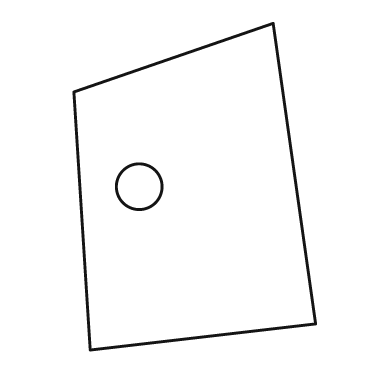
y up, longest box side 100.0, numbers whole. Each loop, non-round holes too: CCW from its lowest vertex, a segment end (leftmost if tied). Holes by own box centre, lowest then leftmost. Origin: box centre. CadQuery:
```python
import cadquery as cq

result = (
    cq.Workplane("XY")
    .moveTo(-32.0, -50.0)
    .lineTo(37.0, -42.0)
    .lineTo(24.0, 50.0)
    .lineTo(-37.0, 29.0)
    .close()
    .moveTo(-17.0, 0.0)
    .circle(7.0)
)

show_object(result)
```